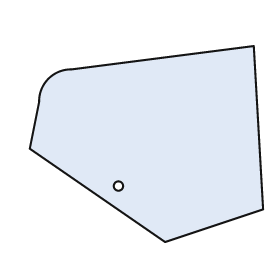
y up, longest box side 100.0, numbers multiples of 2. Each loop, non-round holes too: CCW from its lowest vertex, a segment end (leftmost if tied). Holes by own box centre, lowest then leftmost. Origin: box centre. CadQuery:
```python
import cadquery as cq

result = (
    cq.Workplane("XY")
    .moveTo(8.0, -42.0)
    .lineTo(50.0, -28.0)
    .lineTo(46.0, 42.0)
    .lineTo(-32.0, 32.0)
    .threePointArc((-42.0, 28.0), (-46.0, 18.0))
    .lineTo(-50.0, -2.0)
    .close()
    .moveTo(-12.0, -18.0)
    .circle(2.0)
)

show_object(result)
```